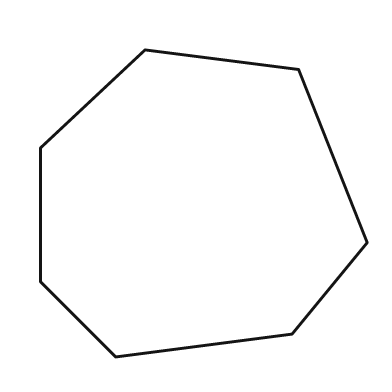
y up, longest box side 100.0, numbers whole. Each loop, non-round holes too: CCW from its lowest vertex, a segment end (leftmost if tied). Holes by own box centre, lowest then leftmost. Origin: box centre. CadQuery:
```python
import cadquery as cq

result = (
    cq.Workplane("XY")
    .moveTo(-27.0, -47.0)
    .lineTo(27.0, -40.0)
    .lineTo(50.0, -12.0)
    .lineTo(29.0, 41.0)
    .lineTo(-18.0, 47.0)
    .lineTo(-50.0, 17.0)
    .lineTo(-50.0, -24.0)
    .close()
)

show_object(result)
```